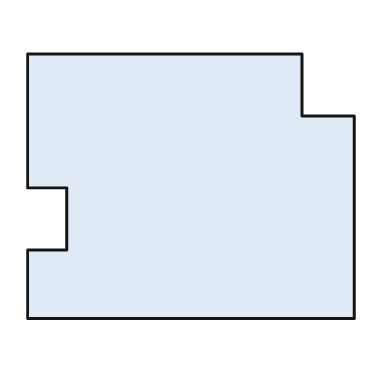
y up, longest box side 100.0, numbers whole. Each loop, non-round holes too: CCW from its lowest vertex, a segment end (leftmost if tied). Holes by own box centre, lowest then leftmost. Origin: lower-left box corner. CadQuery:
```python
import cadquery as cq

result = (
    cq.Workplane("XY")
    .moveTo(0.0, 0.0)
    .lineTo(100.0, 0.0)
    .lineTo(100.0, 62.0)
    .lineTo(84.0, 62.0)
    .lineTo(84.0, 81.0)
    .lineTo(0.0, 81.0)
    .lineTo(0.0, 40.0)
    .lineTo(12.0, 40.0)
    .lineTo(12.0, 21.0)
    .lineTo(0.0, 21.0)
    .close()
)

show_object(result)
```